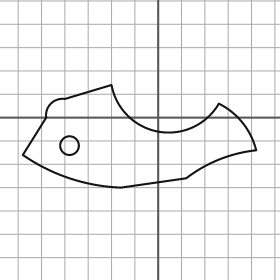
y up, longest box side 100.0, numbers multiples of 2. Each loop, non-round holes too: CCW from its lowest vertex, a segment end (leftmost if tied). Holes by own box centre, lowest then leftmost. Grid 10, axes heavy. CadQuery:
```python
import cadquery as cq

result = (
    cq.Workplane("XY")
    .moveTo(-16.0, -30.0)
    .lineTo(12.0, -26.0)
    .threePointArc((26.0, -18.0), (42.0, -14.0))
    .threePointArc((36.0, -2.0), (26.0, 6.0))
    .threePointArc((0.0, -6.0), (-20.0, 14.0))
    .lineTo(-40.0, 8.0)
    .threePointArc((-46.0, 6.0), (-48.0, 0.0))
    .lineTo(-58.0, -16.0)
    .threePointArc((-38.0, -26.0), (-16.0, -30.0))
    .close()
    .moveTo(-38.0, -12.0)
    .circle(4.0)
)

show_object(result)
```